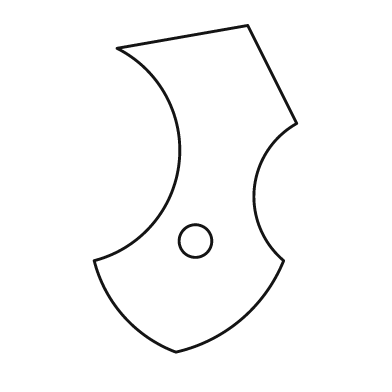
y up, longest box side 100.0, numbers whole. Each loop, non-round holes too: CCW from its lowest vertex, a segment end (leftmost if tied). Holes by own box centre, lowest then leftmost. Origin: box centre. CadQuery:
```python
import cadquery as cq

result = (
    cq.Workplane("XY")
    .moveTo(-6.0, -50.0)
    .threePointArc((14.0, -40.0), (27.0, -22.0))
    .threePointArc((18.0, 0.0), (31.0, 20.0))
    .lineTo(16.0, 50.0)
    .lineTo(-24.0, 43.0)
    .threePointArc((-5.0, 8.0), (-31.0, -22.0))
    .threePointArc((-22.0, -39.0), (-6.0, -50.0))
    .close()
    .moveTo(0.0, -16.0)
    .circle(5.0)
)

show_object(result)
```